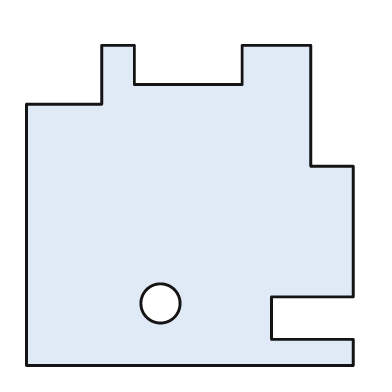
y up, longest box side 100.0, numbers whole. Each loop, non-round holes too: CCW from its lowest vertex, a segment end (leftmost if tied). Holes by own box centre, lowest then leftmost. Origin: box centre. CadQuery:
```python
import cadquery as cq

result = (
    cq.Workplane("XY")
    .moveTo(-50.0, -49.0)
    .lineTo(50.0, -49.0)
    .lineTo(50.0, -41.0)
    .lineTo(25.0, -41.0)
    .lineTo(25.0, -28.0)
    .lineTo(50.0, -28.0)
    .lineTo(50.0, 12.0)
    .lineTo(37.0, 12.0)
    .lineTo(37.0, 49.0)
    .lineTo(16.0, 49.0)
    .lineTo(16.0, 37.0)
    .lineTo(-17.0, 37.0)
    .lineTo(-17.0, 49.0)
    .lineTo(-27.0, 49.0)
    .lineTo(-27.0, 31.0)
    .lineTo(-50.0, 31.0)
    .close()
    .moveTo(-9.0, -30.0)
    .circle(6.0)
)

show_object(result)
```